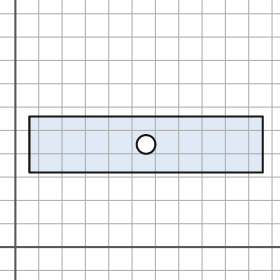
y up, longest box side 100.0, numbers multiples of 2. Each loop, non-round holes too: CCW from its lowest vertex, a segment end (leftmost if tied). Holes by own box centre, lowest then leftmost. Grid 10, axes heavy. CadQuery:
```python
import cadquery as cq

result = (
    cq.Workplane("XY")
    .moveTo(6.0, 32.0)
    .lineTo(106.0, 32.0)
    .lineTo(106.0, 56.0)
    .lineTo(6.0, 56.0)
    .close()
    .moveTo(56.0, 44.0)
    .circle(4.0)
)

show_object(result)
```